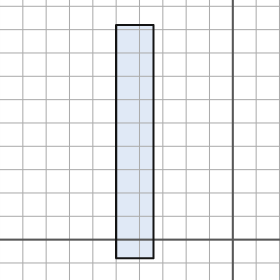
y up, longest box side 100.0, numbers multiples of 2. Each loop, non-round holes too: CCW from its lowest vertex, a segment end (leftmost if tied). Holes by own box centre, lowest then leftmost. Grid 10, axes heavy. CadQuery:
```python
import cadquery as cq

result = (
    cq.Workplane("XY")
    .moveTo(-50.0, -8.0)
    .lineTo(-34.0, -8.0)
    .lineTo(-34.0, 92.0)
    .lineTo(-50.0, 92.0)
    .close()
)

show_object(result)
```